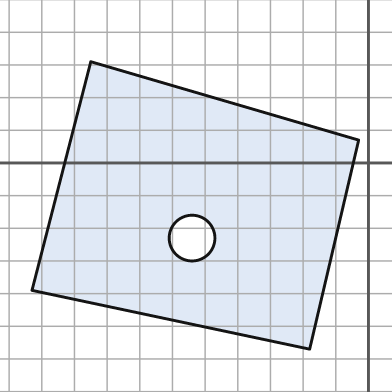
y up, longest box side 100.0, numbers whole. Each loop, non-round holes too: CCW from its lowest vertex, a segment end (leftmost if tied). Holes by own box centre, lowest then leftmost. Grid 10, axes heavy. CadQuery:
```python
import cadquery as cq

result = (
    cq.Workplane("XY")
    .moveTo(-18.0, -57.0)
    .lineTo(-3.0, 7.0)
    .lineTo(-85.0, 31.0)
    .lineTo(-103.0, -39.0)
    .close()
    .moveTo(-54.0, -23.0)
    .circle(7.0)
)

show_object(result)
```